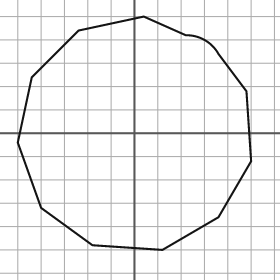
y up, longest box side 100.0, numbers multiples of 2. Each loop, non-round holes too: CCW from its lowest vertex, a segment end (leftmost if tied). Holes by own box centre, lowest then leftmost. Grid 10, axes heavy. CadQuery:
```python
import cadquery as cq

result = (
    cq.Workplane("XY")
    .moveTo(12.0, -50.0)
    .lineTo(36.0, -36.0)
    .lineTo(50.0, -12.0)
    .lineTo(48.0, 18.0)
    .lineTo(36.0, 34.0)
    .threePointArc((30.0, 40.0), (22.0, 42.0))
    .lineTo(4.0, 50.0)
    .lineTo(-24.0, 44.0)
    .lineTo(-44.0, 24.0)
    .lineTo(-50.0, -4.0)
    .lineTo(-40.0, -32.0)
    .lineTo(-18.0, -48.0)
    .close()
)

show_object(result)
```